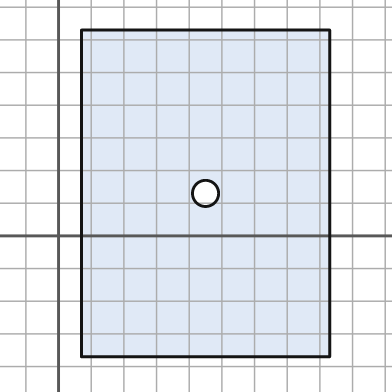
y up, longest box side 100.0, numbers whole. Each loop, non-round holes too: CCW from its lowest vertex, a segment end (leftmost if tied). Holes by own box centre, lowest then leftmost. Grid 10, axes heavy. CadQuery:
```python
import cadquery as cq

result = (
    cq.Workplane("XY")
    .moveTo(7.0, -37.0)
    .lineTo(83.0, -37.0)
    .lineTo(83.0, 63.0)
    .lineTo(7.0, 63.0)
    .close()
    .moveTo(45.0, 13.0)
    .circle(4.0)
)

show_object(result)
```